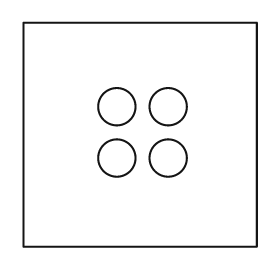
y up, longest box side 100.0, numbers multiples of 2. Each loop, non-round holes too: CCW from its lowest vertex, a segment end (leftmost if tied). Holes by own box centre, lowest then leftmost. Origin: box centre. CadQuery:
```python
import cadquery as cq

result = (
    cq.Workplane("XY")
    .moveTo(-50.0, -48.0)
    .lineTo(50.0, -48.0)
    .lineTo(50.0, 48.0)
    .lineTo(-50.0, 48.0)
    .close()
    .moveTo(-10.0, -10.0)
    .circle(8.0)
    .moveTo(12.0, -10.0)
    .circle(8.0)
    .moveTo(-10.0, 12.0)
    .circle(8.0)
    .moveTo(12.0, 12.0)
    .circle(8.0)
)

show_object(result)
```